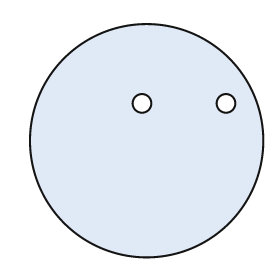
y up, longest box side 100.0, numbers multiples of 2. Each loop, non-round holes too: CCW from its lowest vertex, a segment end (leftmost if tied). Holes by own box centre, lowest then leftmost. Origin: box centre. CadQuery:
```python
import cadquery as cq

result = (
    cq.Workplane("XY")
    .moveTo(0.0, 0.0)
    .circle(50.0)
    .moveTo(-2.0, 16.0)
    .circle(4.0)
    .moveTo(34.0, 16.0)
    .circle(4.0)
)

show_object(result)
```